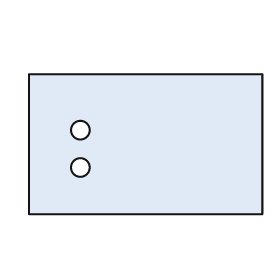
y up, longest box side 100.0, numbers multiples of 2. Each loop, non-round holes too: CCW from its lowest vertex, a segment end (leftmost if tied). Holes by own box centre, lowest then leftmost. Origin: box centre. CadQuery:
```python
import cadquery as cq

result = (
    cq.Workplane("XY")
    .moveTo(-50.0, -30.0)
    .lineTo(50.0, -30.0)
    .lineTo(50.0, 30.0)
    .lineTo(-50.0, 30.0)
    .close()
    .moveTo(-28.0, -10.0)
    .circle(4.0)
    .moveTo(-28.0, 6.0)
    .circle(4.0)
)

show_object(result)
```